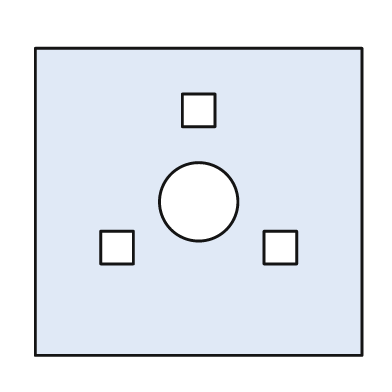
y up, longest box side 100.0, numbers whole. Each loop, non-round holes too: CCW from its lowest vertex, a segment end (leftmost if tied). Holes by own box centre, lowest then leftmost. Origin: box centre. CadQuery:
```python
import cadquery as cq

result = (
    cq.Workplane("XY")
    .moveTo(-50.0, -47.0)
    .lineTo(50.0, -47.0)
    .lineTo(50.0, 47.0)
    .lineTo(-50.0, 47.0)
    .close()
    .moveTo(-30.0, -19.0)
    .lineTo(-20.0, -19.0)
    .lineTo(-20.0, -9.0)
    .lineTo(-30.0, -9.0)
    .close()
    .moveTo(20.0, -19.0)
    .lineTo(30.0, -19.0)
    .lineTo(30.0, -9.0)
    .lineTo(20.0, -9.0)
    .close()
    .moveTo(0.0, 0.0)
    .circle(12.0)
    .moveTo(-5.0, 23.0)
    .lineTo(5.0, 23.0)
    .lineTo(5.0, 33.0)
    .lineTo(-5.0, 33.0)
    .close()
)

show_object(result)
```